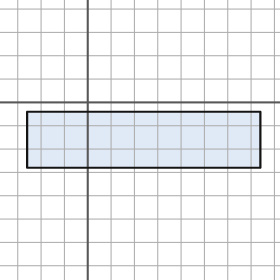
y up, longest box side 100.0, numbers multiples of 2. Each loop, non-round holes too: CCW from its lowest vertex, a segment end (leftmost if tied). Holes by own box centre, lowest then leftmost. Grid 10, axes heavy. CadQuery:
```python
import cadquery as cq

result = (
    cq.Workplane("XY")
    .moveTo(-26.0, -28.0)
    .lineTo(74.0, -28.0)
    .lineTo(74.0, -4.0)
    .lineTo(-26.0, -4.0)
    .close()
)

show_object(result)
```